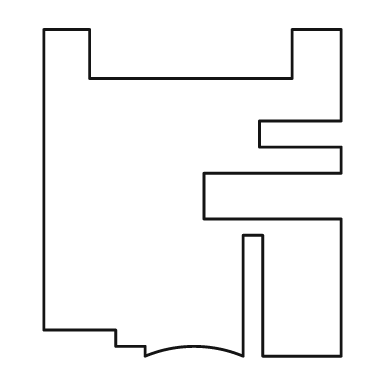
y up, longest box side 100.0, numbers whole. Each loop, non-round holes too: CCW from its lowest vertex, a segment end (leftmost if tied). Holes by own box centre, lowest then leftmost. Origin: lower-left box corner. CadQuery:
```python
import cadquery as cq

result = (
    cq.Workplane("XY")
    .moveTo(31.0, 0.0)
    .threePointArc((46.0, 3.0), (61.0, 0.0))
    .lineTo(61.0, 37.0)
    .lineTo(67.0, 37.0)
    .lineTo(67.0, 0.0)
    .lineTo(91.0, 0.0)
    .lineTo(91.0, 42.0)
    .lineTo(49.0, 42.0)
    .lineTo(49.0, 56.0)
    .lineTo(91.0, 56.0)
    .lineTo(91.0, 64.0)
    .lineTo(66.0, 64.0)
    .lineTo(66.0, 72.0)
    .lineTo(91.0, 72.0)
    .lineTo(91.0, 100.0)
    .lineTo(76.0, 100.0)
    .lineTo(76.0, 85.0)
    .lineTo(14.0, 85.0)
    .lineTo(14.0, 100.0)
    .lineTo(0.0, 100.0)
    .lineTo(0.0, 8.0)
    .lineTo(22.0, 8.0)
    .lineTo(22.0, 3.0)
    .lineTo(31.0, 3.0)
    .close()
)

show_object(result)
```